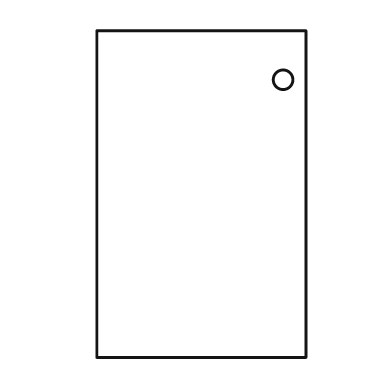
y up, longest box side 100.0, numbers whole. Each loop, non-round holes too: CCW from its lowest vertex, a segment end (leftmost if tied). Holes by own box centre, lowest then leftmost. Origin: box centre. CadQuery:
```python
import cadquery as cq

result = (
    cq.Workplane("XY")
    .moveTo(-32.0, -50.0)
    .lineTo(32.0, -50.0)
    .lineTo(32.0, 50.0)
    .lineTo(-32.0, 50.0)
    .close()
    .moveTo(25.0, 35.0)
    .circle(3.0)
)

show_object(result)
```